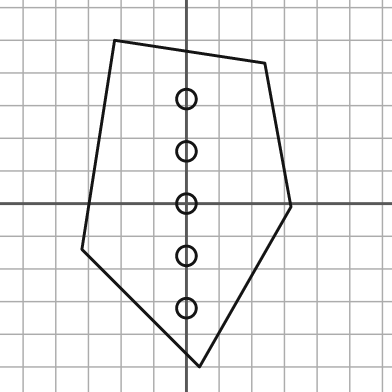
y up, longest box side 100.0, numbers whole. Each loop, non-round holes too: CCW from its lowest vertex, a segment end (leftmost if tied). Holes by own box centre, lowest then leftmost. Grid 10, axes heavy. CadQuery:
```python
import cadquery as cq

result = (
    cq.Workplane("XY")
    .moveTo(4.0, -50.0)
    .lineTo(32.0, -1.0)
    .lineTo(24.0, 43.0)
    .lineTo(-22.0, 50.0)
    .lineTo(-32.0, -14.0)
    .close()
    .moveTo(0.0, -32.0)
    .circle(3.0)
    .moveTo(0.0, -16.0)
    .circle(3.0)
    .moveTo(0.0, 0.0)
    .circle(3.0)
    .moveTo(0.0, 16.0)
    .circle(3.0)
    .moveTo(0.0, 32.0)
    .circle(3.0)
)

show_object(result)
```